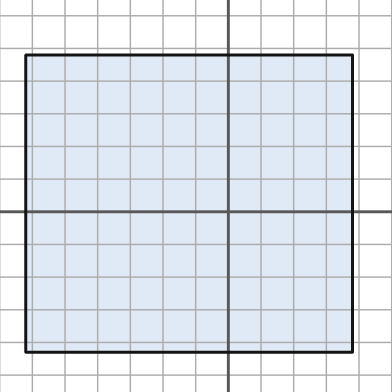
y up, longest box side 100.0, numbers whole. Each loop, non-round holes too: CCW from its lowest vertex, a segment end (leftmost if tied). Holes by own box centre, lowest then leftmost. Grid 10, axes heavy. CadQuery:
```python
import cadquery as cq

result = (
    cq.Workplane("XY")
    .moveTo(-62.0, -43.0)
    .lineTo(38.0, -43.0)
    .lineTo(38.0, 48.0)
    .lineTo(-62.0, 48.0)
    .close()
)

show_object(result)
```